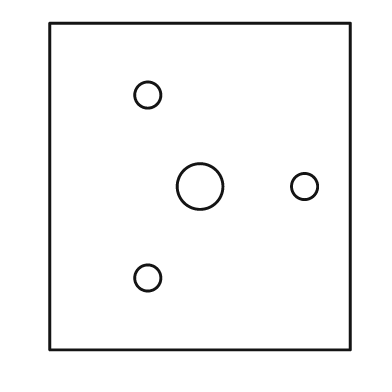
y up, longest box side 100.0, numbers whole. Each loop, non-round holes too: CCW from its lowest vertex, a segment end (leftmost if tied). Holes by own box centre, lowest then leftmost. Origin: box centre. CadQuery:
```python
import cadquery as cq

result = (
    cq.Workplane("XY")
    .moveTo(-46.0, -50.0)
    .lineTo(46.0, -50.0)
    .lineTo(46.0, 50.0)
    .lineTo(-46.0, 50.0)
    .close()
    .moveTo(-16.0, -28.0)
    .circle(4.0)
    .moveTo(0.0, 0.0)
    .circle(7.0)
    .moveTo(32.0, 0.0)
    .circle(4.0)
    .moveTo(-16.0, 28.0)
    .circle(4.0)
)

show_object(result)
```